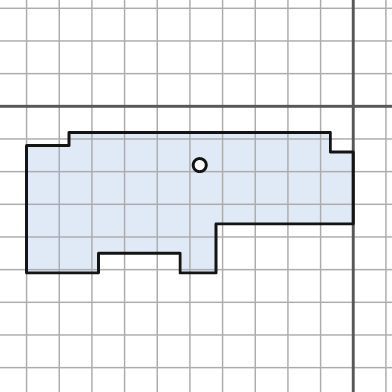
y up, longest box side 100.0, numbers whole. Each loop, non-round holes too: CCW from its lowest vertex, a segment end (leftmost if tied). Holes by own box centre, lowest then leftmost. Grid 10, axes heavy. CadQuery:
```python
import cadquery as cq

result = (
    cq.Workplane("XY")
    .moveTo(-100.0, -51.0)
    .lineTo(-78.0, -51.0)
    .lineTo(-78.0, -45.0)
    .lineTo(-53.0, -45.0)
    .lineTo(-53.0, -51.0)
    .lineTo(-42.0, -51.0)
    .lineTo(-42.0, -36.0)
    .lineTo(0.0, -36.0)
    .lineTo(0.0, -14.0)
    .lineTo(-7.0, -14.0)
    .lineTo(-7.0, -8.0)
    .lineTo(-87.0, -8.0)
    .lineTo(-87.0, -12.0)
    .lineTo(-100.0, -12.0)
    .close()
    .moveTo(-47.0, -18.0)
    .circle(2.0)
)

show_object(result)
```